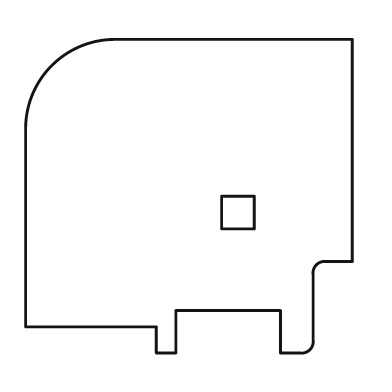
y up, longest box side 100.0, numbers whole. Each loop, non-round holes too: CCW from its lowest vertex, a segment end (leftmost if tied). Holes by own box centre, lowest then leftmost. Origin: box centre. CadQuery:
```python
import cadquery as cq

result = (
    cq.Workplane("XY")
    .moveTo(-10.0, -48.0)
    .lineTo(-4.0, -48.0)
    .lineTo(-4.0, -35.0)
    .lineTo(28.0, -35.0)
    .lineTo(28.0, -48.0)
    .lineTo(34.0, -48.0)
    .threePointArc((37.0, -47.0), (38.0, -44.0))
    .lineTo(38.0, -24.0)
    .threePointArc((39.0, -21.0), (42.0, -20.0))
    .lineTo(50.0, -20.0)
    .lineTo(50.0, 48.0)
    .lineTo(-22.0, 48.0)
    .threePointArc((-42.0, 40.0), (-50.0, 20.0))
    .lineTo(-50.0, -40.0)
    .lineTo(-10.0, -40.0)
    .close()
    .moveTo(10.0, -10.0)
    .lineTo(20.0, -10.0)
    .lineTo(20.0, 0.0)
    .lineTo(10.0, 0.0)
    .close()
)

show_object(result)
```